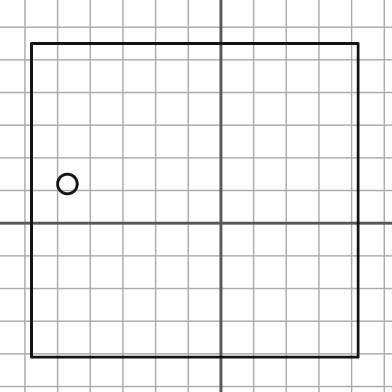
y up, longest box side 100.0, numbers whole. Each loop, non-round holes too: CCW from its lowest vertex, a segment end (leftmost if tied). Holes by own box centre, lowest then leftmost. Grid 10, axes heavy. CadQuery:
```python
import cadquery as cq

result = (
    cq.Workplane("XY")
    .moveTo(-58.0, -41.0)
    .lineTo(42.0, -41.0)
    .lineTo(42.0, 55.0)
    .lineTo(-58.0, 55.0)
    .close()
    .moveTo(-47.0, 12.0)
    .circle(3.0)
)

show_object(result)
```